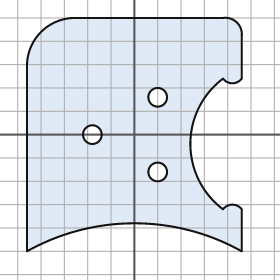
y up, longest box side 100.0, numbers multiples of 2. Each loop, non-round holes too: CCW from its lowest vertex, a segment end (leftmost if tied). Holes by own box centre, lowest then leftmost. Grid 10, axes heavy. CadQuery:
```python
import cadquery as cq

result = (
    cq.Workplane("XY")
    .moveTo(-46.0, -50.0)
    .threePointArc((0.0, -38.0), (46.0, -50.0))
    .lineTo(46.0, -32.0)
    .threePointArc((42.0, -30.0), (38.0, -32.0))
    .threePointArc((24.0, -4.0), (38.0, 24.0))
    .threePointArc((42.0, 22.0), (46.0, 24.0))
    .lineTo(46.0, 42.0)
    .threePointArc((44.0, 48.0), (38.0, 50.0))
    .lineTo(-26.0, 50.0)
    .threePointArc((-40.0, 44.0), (-46.0, 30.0))
    .close()
    .moveTo(10.0, -16.0)
    .circle(4.0)
    .moveTo(-18.0, 0.0)
    .circle(4.0)
    .moveTo(10.0, 16.0)
    .circle(4.0)
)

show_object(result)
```